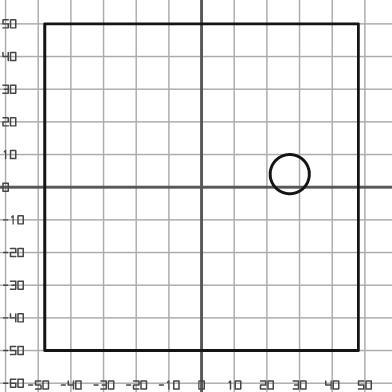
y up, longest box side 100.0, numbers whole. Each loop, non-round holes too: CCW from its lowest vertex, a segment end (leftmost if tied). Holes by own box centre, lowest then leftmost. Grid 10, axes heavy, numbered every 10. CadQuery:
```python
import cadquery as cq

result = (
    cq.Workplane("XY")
    .moveTo(-48.0, -50.0)
    .lineTo(48.0, -50.0)
    .lineTo(48.0, 50.0)
    .lineTo(-48.0, 50.0)
    .close()
    .moveTo(27.0, 4.0)
    .circle(6.0)
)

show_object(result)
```